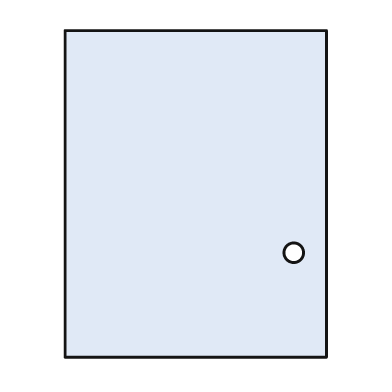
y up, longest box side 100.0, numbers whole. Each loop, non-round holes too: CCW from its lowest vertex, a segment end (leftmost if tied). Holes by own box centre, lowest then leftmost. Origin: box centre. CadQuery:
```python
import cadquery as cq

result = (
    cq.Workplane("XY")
    .moveTo(-40.0, -50.0)
    .lineTo(40.0, -50.0)
    .lineTo(40.0, 50.0)
    .lineTo(-40.0, 50.0)
    .close()
    .moveTo(30.0, -18.0)
    .circle(3.0)
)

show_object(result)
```